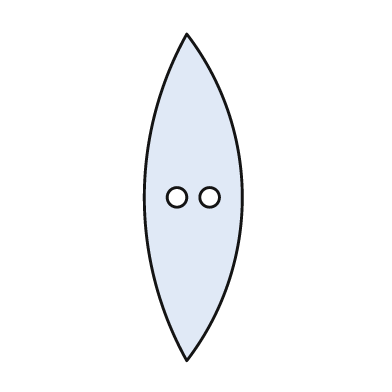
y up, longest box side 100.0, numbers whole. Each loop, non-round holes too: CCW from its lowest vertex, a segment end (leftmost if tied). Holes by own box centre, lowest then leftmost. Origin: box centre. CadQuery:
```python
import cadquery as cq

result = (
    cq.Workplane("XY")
    .moveTo(-2.0, -50.0)
    .threePointArc((15.0, 0.0), (-2.0, 50.0))
    .threePointArc((-15.0, 0.0), (-2.0, -50.0))
    .close()
    .moveTo(-5.0, 0.0)
    .circle(3.0)
    .moveTo(5.0, 0.0)
    .circle(3.0)
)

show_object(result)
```